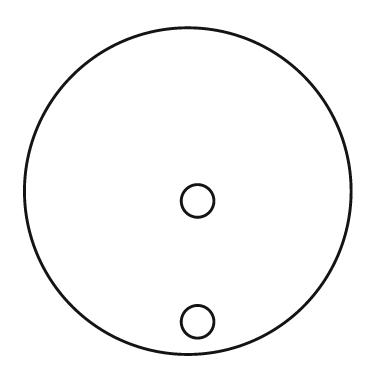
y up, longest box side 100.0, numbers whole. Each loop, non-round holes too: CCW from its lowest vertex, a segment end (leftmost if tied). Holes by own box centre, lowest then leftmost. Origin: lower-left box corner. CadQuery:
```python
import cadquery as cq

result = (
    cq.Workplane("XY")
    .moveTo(50.0, 50.0)
    .circle(50.0)
    .moveTo(53.0, 10.0)
    .circle(5.0)
    .moveTo(53.0, 47.0)
    .circle(5.0)
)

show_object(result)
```